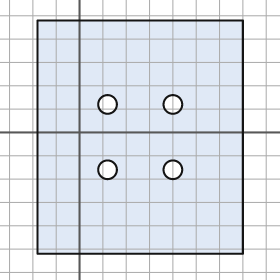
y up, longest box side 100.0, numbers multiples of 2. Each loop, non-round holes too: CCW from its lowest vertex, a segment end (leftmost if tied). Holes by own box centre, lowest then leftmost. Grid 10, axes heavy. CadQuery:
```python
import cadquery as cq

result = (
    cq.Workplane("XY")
    .moveTo(-18.0, -52.0)
    .lineTo(70.0, -52.0)
    .lineTo(70.0, 48.0)
    .lineTo(-18.0, 48.0)
    .close()
    .moveTo(12.0, -16.0)
    .circle(4.0)
    .moveTo(40.0, -16.0)
    .circle(4.0)
    .moveTo(12.0, 12.0)
    .circle(4.0)
    .moveTo(40.0, 12.0)
    .circle(4.0)
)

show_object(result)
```